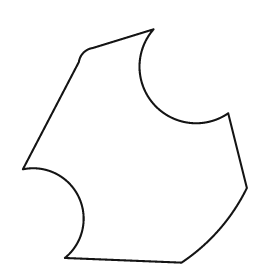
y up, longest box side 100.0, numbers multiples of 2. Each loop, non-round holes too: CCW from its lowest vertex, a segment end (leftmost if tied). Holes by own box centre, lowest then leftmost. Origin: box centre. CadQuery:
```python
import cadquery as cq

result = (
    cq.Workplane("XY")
    .moveTo(20.0, -50.0)
    .threePointArc((36.0, -36.0), (48.0, -18.0))
    .lineTo(40.0, 14.0)
    .threePointArc((8.0, 18.0), (8.0, 50.0))
    .lineTo(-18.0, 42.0)
    .threePointArc((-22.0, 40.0), (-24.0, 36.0))
    .lineTo(-48.0, -10.0)
    .threePointArc((-24.0, -22.0), (-30.0, -48.0))
    .close()
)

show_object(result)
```